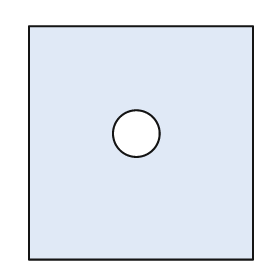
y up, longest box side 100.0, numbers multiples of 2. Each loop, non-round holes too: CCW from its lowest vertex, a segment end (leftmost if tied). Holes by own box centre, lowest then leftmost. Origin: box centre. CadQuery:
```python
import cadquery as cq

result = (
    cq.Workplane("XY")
    .moveTo(-48.0, -50.0)
    .lineTo(48.0, -50.0)
    .lineTo(48.0, 50.0)
    .lineTo(-48.0, 50.0)
    .close()
    .moveTo(-2.0, 4.0)
    .circle(10.0)
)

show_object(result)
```